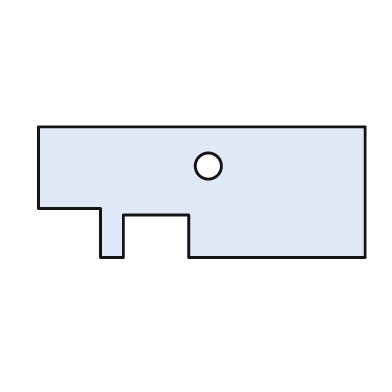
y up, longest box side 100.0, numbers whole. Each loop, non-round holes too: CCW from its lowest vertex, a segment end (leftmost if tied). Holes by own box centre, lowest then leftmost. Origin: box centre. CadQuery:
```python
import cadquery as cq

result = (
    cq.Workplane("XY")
    .moveTo(-31.0, -20.0)
    .lineTo(-24.0, -20.0)
    .lineTo(-24.0, -7.0)
    .lineTo(-4.0, -7.0)
    .lineTo(-4.0, -20.0)
    .lineTo(50.0, -20.0)
    .lineTo(50.0, 20.0)
    .lineTo(-50.0, 20.0)
    .lineTo(-50.0, -5.0)
    .lineTo(-31.0, -5.0)
    .close()
    .moveTo(2.0, 8.0)
    .circle(4.0)
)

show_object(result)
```